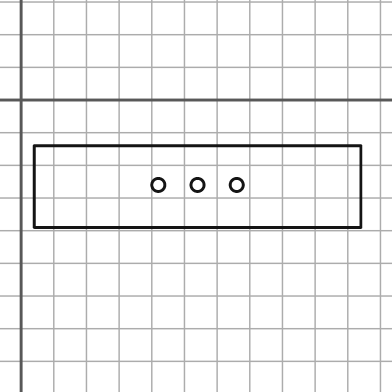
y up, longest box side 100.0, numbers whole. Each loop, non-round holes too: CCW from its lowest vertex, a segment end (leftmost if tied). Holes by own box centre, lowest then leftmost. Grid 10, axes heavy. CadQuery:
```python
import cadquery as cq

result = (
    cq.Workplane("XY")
    .moveTo(4.0, -39.0)
    .lineTo(104.0, -39.0)
    .lineTo(104.0, -14.0)
    .lineTo(4.0, -14.0)
    .close()
    .moveTo(42.0, -26.0)
    .circle(2.0)
    .moveTo(54.0, -26.0)
    .circle(2.0)
    .moveTo(66.0, -26.0)
    .circle(2.0)
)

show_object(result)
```